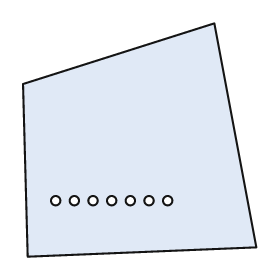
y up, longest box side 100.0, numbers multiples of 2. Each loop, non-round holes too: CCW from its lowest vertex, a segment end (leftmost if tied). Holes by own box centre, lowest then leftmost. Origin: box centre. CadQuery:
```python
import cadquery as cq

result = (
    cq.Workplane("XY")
    .moveTo(-48.0, -50.0)
    .lineTo(50.0, -46.0)
    .lineTo(32.0, 50.0)
    .lineTo(-50.0, 24.0)
    .close()
    .moveTo(-36.0, -26.0)
    .circle(2.0)
    .moveTo(-28.0, -26.0)
    .circle(2.0)
    .moveTo(-20.0, -26.0)
    .circle(2.0)
    .moveTo(-12.0, -26.0)
    .circle(2.0)
    .moveTo(-4.0, -26.0)
    .circle(2.0)
    .moveTo(4.0, -26.0)
    .circle(2.0)
    .moveTo(12.0, -26.0)
    .circle(2.0)
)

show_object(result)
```